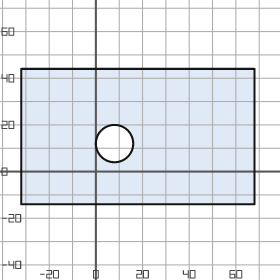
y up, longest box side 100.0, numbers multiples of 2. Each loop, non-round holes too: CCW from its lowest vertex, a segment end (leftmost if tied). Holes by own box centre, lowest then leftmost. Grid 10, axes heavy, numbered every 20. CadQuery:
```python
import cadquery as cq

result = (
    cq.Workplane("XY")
    .moveTo(-32.0, -14.0)
    .lineTo(68.0, -14.0)
    .lineTo(68.0, 44.0)
    .lineTo(-32.0, 44.0)
    .close()
    .moveTo(8.0, 12.0)
    .circle(8.0)
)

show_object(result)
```